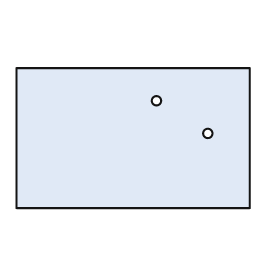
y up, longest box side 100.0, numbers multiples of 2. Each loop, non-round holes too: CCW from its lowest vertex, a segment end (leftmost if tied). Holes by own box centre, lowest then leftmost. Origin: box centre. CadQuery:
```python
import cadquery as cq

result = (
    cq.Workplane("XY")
    .moveTo(-50.0, -30.0)
    .lineTo(50.0, -30.0)
    .lineTo(50.0, 30.0)
    .lineTo(-50.0, 30.0)
    .close()
    .moveTo(32.0, 2.0)
    .circle(2.0)
    .moveTo(10.0, 16.0)
    .circle(2.0)
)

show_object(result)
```